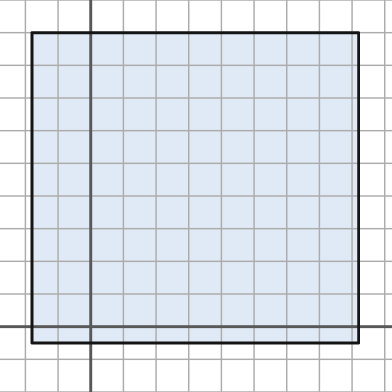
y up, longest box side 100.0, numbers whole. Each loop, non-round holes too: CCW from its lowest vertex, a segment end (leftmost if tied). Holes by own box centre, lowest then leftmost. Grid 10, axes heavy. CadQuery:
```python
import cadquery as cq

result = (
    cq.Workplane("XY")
    .moveTo(-18.0, -5.0)
    .lineTo(82.0, -5.0)
    .lineTo(82.0, 90.0)
    .lineTo(-18.0, 90.0)
    .close()
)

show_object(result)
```